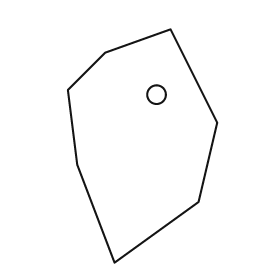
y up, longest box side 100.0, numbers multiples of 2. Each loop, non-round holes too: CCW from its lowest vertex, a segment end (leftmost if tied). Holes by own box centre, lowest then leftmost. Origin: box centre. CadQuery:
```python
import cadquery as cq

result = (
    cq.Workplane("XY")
    .moveTo(-12.0, -50.0)
    .lineTo(24.0, -24.0)
    .lineTo(32.0, 10.0)
    .lineTo(12.0, 50.0)
    .lineTo(-16.0, 40.0)
    .lineTo(-32.0, 24.0)
    .lineTo(-28.0, -8.0)
    .close()
    .moveTo(6.0, 22.0)
    .circle(4.0)
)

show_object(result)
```